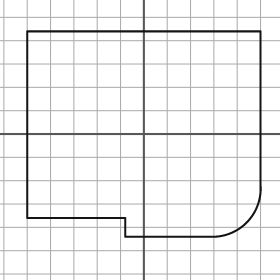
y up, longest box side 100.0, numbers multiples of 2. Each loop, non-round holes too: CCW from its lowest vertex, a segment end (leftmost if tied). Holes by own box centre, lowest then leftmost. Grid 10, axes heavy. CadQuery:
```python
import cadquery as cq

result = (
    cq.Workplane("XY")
    .moveTo(-8.0, -44.0)
    .lineTo(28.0, -44.0)
    .threePointArc((44.0, -38.0), (50.0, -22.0))
    .lineTo(50.0, 44.0)
    .lineTo(-50.0, 44.0)
    .lineTo(-50.0, -36.0)
    .lineTo(-8.0, -36.0)
    .close()
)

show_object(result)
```